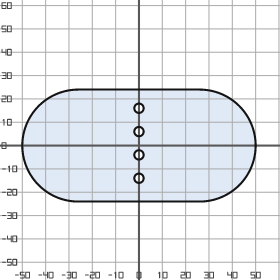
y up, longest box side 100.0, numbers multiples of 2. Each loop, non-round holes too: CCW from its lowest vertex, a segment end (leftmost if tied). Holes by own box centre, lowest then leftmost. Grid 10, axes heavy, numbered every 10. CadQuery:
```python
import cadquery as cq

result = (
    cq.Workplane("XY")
    .moveTo(-26.0, -24.0)
    .lineTo(26.0, -24.0)
    .threePointArc((50.0, 0.0), (26.0, 24.0))
    .lineTo(-26.0, 24.0)
    .threePointArc((-50.0, 0.0), (-26.0, -24.0))
    .close()
    .moveTo(0.0, -14.0)
    .circle(2.0)
    .moveTo(0.0, -4.0)
    .circle(2.0)
    .moveTo(0.0, 6.0)
    .circle(2.0)
    .moveTo(0.0, 16.0)
    .circle(2.0)
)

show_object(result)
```